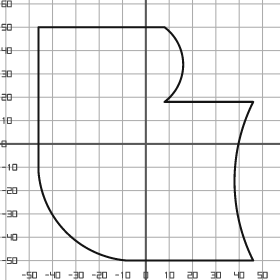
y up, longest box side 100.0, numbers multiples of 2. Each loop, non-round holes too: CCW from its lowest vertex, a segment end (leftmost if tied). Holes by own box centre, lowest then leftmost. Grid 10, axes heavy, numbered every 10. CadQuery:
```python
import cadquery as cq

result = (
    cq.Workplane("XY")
    .moveTo(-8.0, -50.0)
    .lineTo(46.0, -50.0)
    .threePointArc((38.0, -16.0), (46.0, 18.0))
    .lineTo(8.0, 18.0)
    .threePointArc((16.0, 34.0), (8.0, 50.0))
    .lineTo(-46.0, 50.0)
    .lineTo(-46.0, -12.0)
    .threePointArc((-34.0, -38.0), (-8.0, -50.0))
    .close()
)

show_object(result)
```